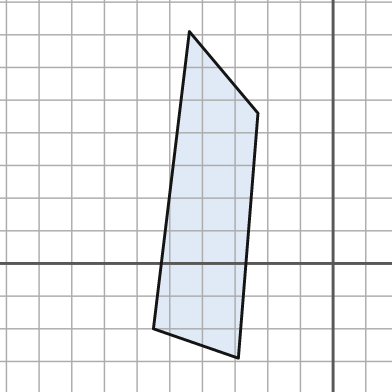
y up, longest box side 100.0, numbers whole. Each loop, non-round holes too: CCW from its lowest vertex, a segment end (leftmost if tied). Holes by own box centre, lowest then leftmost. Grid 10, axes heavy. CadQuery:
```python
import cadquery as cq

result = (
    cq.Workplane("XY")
    .moveTo(-29.0, -29.0)
    .lineTo(-23.0, 46.0)
    .lineTo(-44.0, 71.0)
    .lineTo(-55.0, -20.0)
    .close()
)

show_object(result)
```